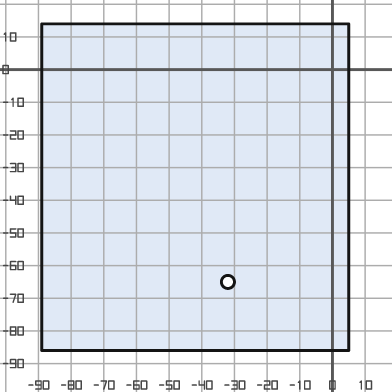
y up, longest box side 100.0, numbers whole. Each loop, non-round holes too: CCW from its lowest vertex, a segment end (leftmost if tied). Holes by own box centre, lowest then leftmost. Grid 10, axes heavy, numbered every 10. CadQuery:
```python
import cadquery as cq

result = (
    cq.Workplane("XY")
    .moveTo(-89.0, -86.0)
    .lineTo(5.0, -86.0)
    .lineTo(5.0, 14.0)
    .lineTo(-89.0, 14.0)
    .close()
    .moveTo(-32.0, -65.0)
    .circle(2.0)
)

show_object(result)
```